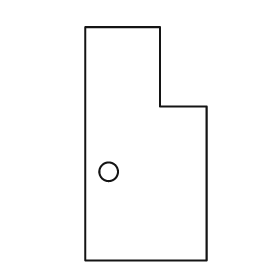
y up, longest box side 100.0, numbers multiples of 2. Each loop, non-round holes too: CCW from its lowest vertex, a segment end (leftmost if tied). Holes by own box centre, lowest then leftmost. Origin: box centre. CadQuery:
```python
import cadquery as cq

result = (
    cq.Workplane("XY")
    .moveTo(-26.0, -50.0)
    .lineTo(26.0, -50.0)
    .lineTo(26.0, 16.0)
    .lineTo(6.0, 16.0)
    .lineTo(6.0, 50.0)
    .lineTo(-26.0, 50.0)
    .close()
    .moveTo(-16.0, -12.0)
    .circle(4.0)
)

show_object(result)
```